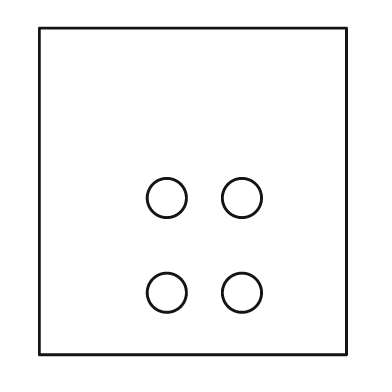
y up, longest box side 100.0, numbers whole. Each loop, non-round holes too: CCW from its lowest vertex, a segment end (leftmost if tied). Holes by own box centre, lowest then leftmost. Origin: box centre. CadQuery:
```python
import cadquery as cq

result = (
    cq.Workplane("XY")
    .moveTo(-47.0, -50.0)
    .lineTo(47.0, -50.0)
    .lineTo(47.0, 50.0)
    .lineTo(-47.0, 50.0)
    .close()
    .moveTo(-8.0, -31.0)
    .circle(6.0)
    .moveTo(15.0, -31.0)
    .circle(6.0)
    .moveTo(-8.0, -2.0)
    .circle(6.0)
    .moveTo(15.0, -2.0)
    .circle(6.0)
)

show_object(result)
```